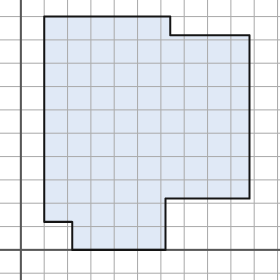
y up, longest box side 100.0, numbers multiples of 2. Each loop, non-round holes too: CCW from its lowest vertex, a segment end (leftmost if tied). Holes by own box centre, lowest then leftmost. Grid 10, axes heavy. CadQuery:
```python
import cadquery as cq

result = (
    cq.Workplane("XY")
    .moveTo(22.0, 0.0)
    .lineTo(62.0, 0.0)
    .lineTo(62.0, 22.0)
    .lineTo(98.0, 22.0)
    .lineTo(98.0, 92.0)
    .lineTo(64.0, 92.0)
    .lineTo(64.0, 100.0)
    .lineTo(10.0, 100.0)
    .lineTo(10.0, 12.0)
    .lineTo(22.0, 12.0)
    .close()
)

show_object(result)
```